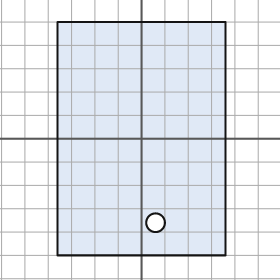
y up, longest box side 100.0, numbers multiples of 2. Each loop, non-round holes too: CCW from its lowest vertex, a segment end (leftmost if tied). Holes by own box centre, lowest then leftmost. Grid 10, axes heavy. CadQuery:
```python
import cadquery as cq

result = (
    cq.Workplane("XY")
    .moveTo(-36.0, -50.0)
    .lineTo(36.0, -50.0)
    .lineTo(36.0, 50.0)
    .lineTo(-36.0, 50.0)
    .close()
    .moveTo(6.0, -36.0)
    .circle(4.0)
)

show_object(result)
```